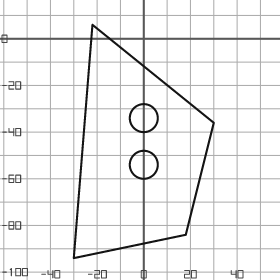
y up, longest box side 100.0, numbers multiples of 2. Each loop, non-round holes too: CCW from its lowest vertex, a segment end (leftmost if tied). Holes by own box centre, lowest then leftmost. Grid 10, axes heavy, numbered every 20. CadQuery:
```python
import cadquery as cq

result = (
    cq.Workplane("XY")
    .moveTo(-30.0, -94.0)
    .lineTo(18.0, -84.0)
    .lineTo(30.0, -36.0)
    .lineTo(-22.0, 6.0)
    .close()
    .moveTo(0.0, -54.0)
    .circle(6.0)
    .moveTo(0.0, -34.0)
    .circle(6.0)
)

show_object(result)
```